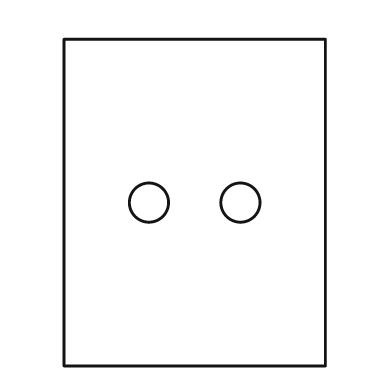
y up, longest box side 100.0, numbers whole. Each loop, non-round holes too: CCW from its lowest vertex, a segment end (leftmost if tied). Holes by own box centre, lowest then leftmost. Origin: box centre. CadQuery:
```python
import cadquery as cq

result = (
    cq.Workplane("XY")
    .moveTo(-40.0, -50.0)
    .lineTo(40.0, -50.0)
    .lineTo(40.0, 50.0)
    .lineTo(-40.0, 50.0)
    .close()
    .moveTo(-14.0, 0.0)
    .circle(6.0)
    .moveTo(14.0, 0.0)
    .circle(6.0)
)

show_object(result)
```